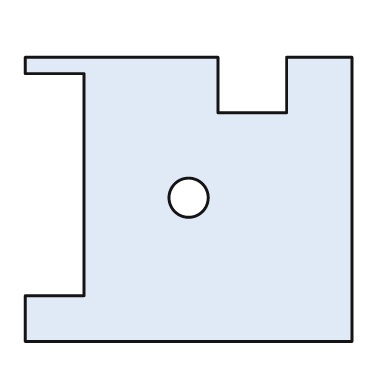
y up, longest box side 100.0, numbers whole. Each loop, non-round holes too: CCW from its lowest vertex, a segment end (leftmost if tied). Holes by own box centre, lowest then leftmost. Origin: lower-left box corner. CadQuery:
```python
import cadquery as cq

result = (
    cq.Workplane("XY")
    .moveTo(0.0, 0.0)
    .lineTo(100.0, 0.0)
    .lineTo(100.0, 87.0)
    .lineTo(80.0, 87.0)
    .lineTo(80.0, 70.0)
    .lineTo(59.0, 70.0)
    .lineTo(59.0, 87.0)
    .lineTo(0.0, 87.0)
    .lineTo(0.0, 82.0)
    .lineTo(18.0, 82.0)
    .lineTo(18.0, 14.0)
    .lineTo(0.0, 14.0)
    .close()
    .moveTo(50.0, 44.0)
    .circle(6.0)
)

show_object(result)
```